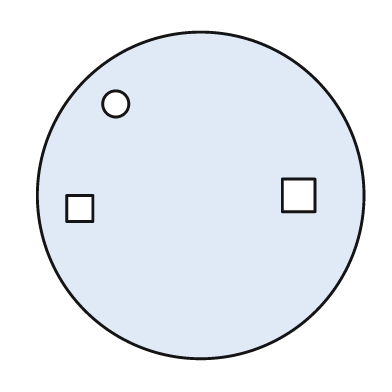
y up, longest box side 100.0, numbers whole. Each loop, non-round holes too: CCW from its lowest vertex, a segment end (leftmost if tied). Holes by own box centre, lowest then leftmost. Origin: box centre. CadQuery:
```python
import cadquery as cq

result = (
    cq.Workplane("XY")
    .moveTo(0.0, 0.0)
    .circle(50.0)
    .moveTo(-41.0, -8.0)
    .lineTo(-33.0, -8.0)
    .lineTo(-33.0, 0.0)
    .lineTo(-41.0, 0.0)
    .close()
    .moveTo(25.0, -5.0)
    .lineTo(35.0, -5.0)
    .lineTo(35.0, 5.0)
    .lineTo(25.0, 5.0)
    .close()
    .moveTo(-26.0, 28.0)
    .circle(4.0)
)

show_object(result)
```